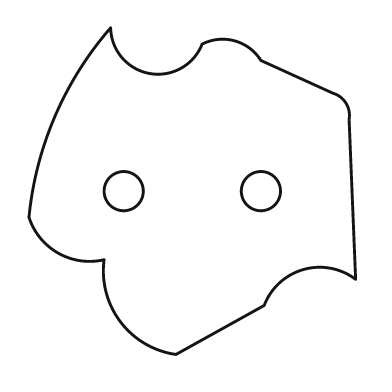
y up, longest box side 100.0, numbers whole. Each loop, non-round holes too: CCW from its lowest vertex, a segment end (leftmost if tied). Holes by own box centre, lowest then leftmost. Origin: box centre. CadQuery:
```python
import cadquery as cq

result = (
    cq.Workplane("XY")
    .moveTo(-5.0, -50.0)
    .lineTo(22.0, -35.0)
    .threePointArc((34.0, -24.0), (50.0, -27.0))
    .lineTo(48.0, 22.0)
    .threePointArc((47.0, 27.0), (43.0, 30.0))
    .lineTo(21.0, 40.0)
    .threePointArc((13.0, 46.0), (3.0, 45.0))
    .threePointArc((-13.0, 36.0), (-25.0, 50.0))
    .threePointArc((-42.0, 23.0), (-50.0, -8.0))
    .threePointArc((-41.0, -19.0), (-27.0, -21.0))
    .threePointArc((-22.0, -40.0), (-5.0, -50.0))
    .close()
    .moveTo(-21.0, 0.0)
    .circle(6.0)
    .moveTo(21.0, 0.0)
    .circle(6.0)
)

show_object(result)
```